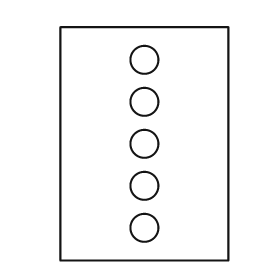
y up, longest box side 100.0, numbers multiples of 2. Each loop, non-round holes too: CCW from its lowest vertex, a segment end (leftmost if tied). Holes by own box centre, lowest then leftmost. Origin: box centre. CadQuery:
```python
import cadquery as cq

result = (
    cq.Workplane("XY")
    .moveTo(-36.0, -50.0)
    .lineTo(36.0, -50.0)
    .lineTo(36.0, 50.0)
    .lineTo(-36.0, 50.0)
    .close()
    .moveTo(0.0, -36.0)
    .circle(6.0)
    .moveTo(0.0, -18.0)
    .circle(6.0)
    .moveTo(0.0, 0.0)
    .circle(6.0)
    .moveTo(0.0, 18.0)
    .circle(6.0)
    .moveTo(0.0, 36.0)
    .circle(6.0)
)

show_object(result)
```